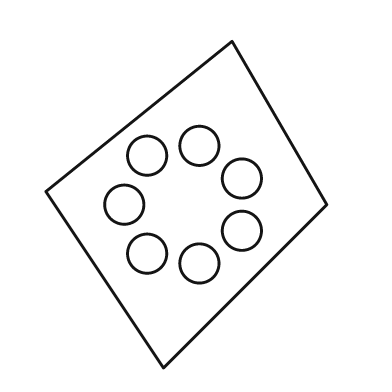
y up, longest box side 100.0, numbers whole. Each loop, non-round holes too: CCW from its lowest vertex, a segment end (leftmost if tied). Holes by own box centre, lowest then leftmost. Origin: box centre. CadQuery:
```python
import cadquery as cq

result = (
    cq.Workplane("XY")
    .moveTo(-7.0, -50.0)
    .lineTo(43.0, 0.0)
    .lineTo(14.0, 50.0)
    .lineTo(-43.0, 4.0)
    .close()
    .moveTo(4.0, -18.0)
    .circle(6.0)
    .moveTo(-12.0, -15.0)
    .circle(6.0)
    .moveTo(17.0, -8.0)
    .circle(6.0)
    .moveTo(-19.0, 0.0)
    .circle(6.0)
    .moveTo(17.0, 8.0)
    .circle(6.0)
    .moveTo(-12.0, 15.0)
    .circle(6.0)
    .moveTo(4.0, 18.0)
    .circle(6.0)
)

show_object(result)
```